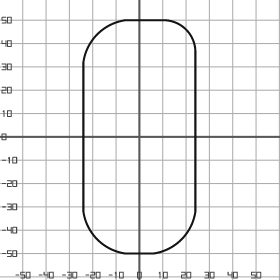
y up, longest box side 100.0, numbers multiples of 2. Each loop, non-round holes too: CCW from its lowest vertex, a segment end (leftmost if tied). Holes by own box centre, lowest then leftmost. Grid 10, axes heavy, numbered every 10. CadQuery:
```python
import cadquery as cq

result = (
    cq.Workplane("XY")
    .moveTo(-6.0, -50.0)
    .lineTo(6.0, -50.0)
    .threePointArc((18.0, -44.0), (24.0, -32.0))
    .lineTo(24.0, 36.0)
    .threePointArc((20.0, 46.0), (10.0, 50.0))
    .lineTo(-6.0, 50.0)
    .threePointArc((-18.0, 44.0), (-24.0, 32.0))
    .lineTo(-24.0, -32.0)
    .threePointArc((-18.0, -44.0), (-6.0, -50.0))
    .close()
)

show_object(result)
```